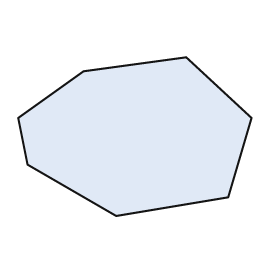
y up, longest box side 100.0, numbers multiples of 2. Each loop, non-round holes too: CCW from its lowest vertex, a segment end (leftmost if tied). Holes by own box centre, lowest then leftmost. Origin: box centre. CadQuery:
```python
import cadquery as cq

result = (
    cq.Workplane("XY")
    .moveTo(-8.0, -34.0)
    .lineTo(40.0, -26.0)
    .lineTo(50.0, 8.0)
    .lineTo(22.0, 34.0)
    .lineTo(-22.0, 28.0)
    .lineTo(-50.0, 8.0)
    .lineTo(-46.0, -12.0)
    .close()
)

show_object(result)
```